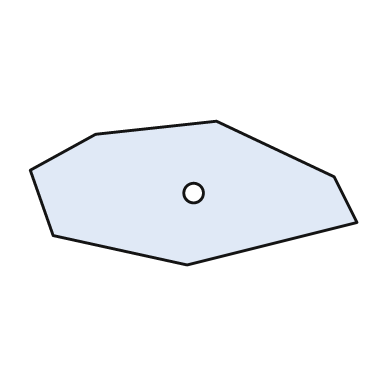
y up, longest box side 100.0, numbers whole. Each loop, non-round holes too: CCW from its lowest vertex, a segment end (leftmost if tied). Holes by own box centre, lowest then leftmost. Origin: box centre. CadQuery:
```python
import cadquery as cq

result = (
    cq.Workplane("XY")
    .moveTo(-2.0, -22.0)
    .lineTo(50.0, -9.0)
    .lineTo(43.0, 5.0)
    .lineTo(7.0, 22.0)
    .lineTo(-30.0, 18.0)
    .lineTo(-50.0, 7.0)
    .lineTo(-43.0, -13.0)
    .close()
    .moveTo(0.0, 0.0)
    .circle(3.0)
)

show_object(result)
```